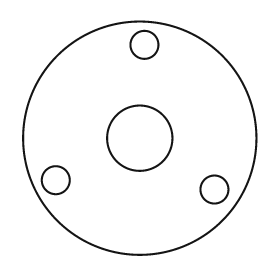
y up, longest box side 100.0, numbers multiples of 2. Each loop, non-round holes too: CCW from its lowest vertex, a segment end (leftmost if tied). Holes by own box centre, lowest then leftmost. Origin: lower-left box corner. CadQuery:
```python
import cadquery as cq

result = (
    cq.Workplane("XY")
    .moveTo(50.0, 50.0)
    .circle(50.0)
    .moveTo(82.0, 28.0)
    .circle(6.0)
    .moveTo(14.0, 32.0)
    .circle(6.0)
    .moveTo(50.0, 50.0)
    .circle(14.0)
    .moveTo(52.0, 90.0)
    .circle(6.0)
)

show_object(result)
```